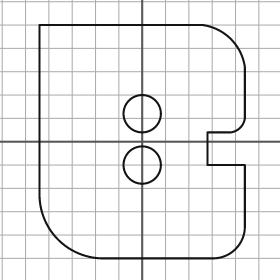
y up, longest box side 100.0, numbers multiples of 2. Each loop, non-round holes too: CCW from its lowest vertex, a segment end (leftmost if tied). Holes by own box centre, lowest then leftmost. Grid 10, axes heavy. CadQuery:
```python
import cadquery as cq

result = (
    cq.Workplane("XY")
    .moveTo(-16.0, -50.0)
    .lineTo(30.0, -50.0)
    .threePointArc((40.0, -46.0), (44.0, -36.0))
    .lineTo(44.0, -10.0)
    .lineTo(28.0, -10.0)
    .lineTo(28.0, 4.0)
    .lineTo(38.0, 4.0)
    .threePointArc((42.0, 6.0), (44.0, 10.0))
    .lineTo(44.0, 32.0)
    .threePointArc((38.0, 44.0), (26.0, 50.0))
    .lineTo(-44.0, 50.0)
    .lineTo(-44.0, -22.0)
    .threePointArc((-36.0, -42.0), (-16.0, -50.0))
    .close()
    .moveTo(0.0, -10.0)
    .circle(8.0)
    .moveTo(0.0, 12.0)
    .circle(8.0)
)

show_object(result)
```